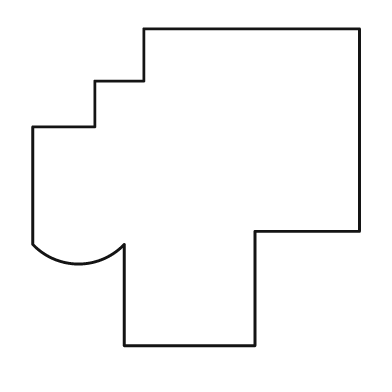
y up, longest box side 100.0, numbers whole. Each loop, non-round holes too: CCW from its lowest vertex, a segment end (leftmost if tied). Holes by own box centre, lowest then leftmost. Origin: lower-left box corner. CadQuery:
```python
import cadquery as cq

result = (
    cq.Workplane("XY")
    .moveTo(28.0, 0.0)
    .lineTo(68.0, 0.0)
    .lineTo(68.0, 35.0)
    .lineTo(100.0, 35.0)
    .lineTo(100.0, 97.0)
    .lineTo(34.0, 97.0)
    .lineTo(34.0, 81.0)
    .lineTo(19.0, 81.0)
    .lineTo(19.0, 67.0)
    .lineTo(0.0, 67.0)
    .lineTo(0.0, 31.0)
    .threePointArc((14.0, 25.0), (28.0, 31.0))
    .close()
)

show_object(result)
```